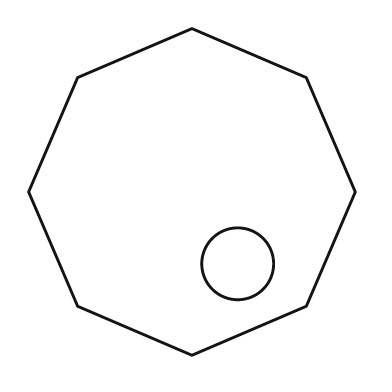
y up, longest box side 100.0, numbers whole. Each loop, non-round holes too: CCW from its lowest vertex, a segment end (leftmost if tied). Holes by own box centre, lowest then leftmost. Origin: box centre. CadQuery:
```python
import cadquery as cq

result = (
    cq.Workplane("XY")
    .moveTo(0.0, -50.0)
    .lineTo(35.0, -35.0)
    .lineTo(50.0, 0.0)
    .lineTo(35.0, 35.0)
    .lineTo(0.0, 50.0)
    .lineTo(-35.0, 35.0)
    .lineTo(-50.0, 0.0)
    .lineTo(-35.0, -35.0)
    .close()
    .moveTo(14.0, -22.0)
    .circle(11.0)
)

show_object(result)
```